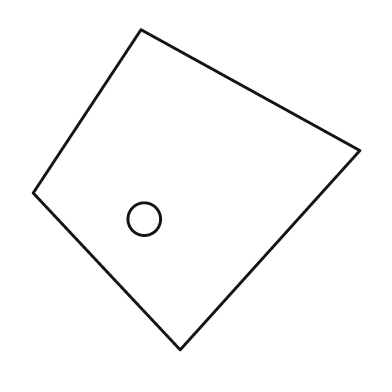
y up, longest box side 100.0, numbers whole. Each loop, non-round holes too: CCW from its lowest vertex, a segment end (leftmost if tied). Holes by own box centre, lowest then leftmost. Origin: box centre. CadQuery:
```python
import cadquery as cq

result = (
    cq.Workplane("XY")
    .moveTo(-5.0, -49.0)
    .lineTo(50.0, 12.0)
    .lineTo(-17.0, 49.0)
    .lineTo(-50.0, -1.0)
    .close()
    .moveTo(-16.0, -9.0)
    .circle(5.0)
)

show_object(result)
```